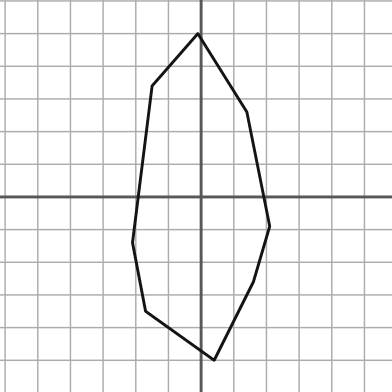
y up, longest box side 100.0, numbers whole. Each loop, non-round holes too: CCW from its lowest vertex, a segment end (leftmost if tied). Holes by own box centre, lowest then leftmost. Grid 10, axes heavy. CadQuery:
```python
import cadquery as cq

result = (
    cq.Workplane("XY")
    .moveTo(4.0, -50.0)
    .lineTo(16.0, -26.0)
    .lineTo(21.0, -9.0)
    .lineTo(14.0, 26.0)
    .lineTo(-1.0, 50.0)
    .lineTo(-15.0, 34.0)
    .lineTo(-21.0, -14.0)
    .lineTo(-17.0, -35.0)
    .close()
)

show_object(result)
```